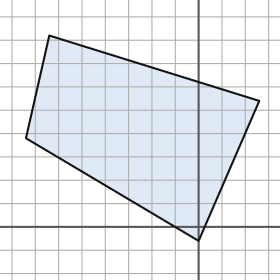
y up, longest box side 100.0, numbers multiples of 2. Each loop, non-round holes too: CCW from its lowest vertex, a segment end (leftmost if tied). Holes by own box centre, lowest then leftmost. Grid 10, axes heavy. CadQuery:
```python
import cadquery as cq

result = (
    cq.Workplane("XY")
    .moveTo(0.0, -6.0)
    .lineTo(26.0, 54.0)
    .lineTo(-64.0, 82.0)
    .lineTo(-74.0, 38.0)
    .close()
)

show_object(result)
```